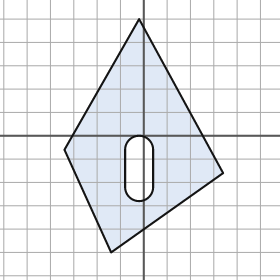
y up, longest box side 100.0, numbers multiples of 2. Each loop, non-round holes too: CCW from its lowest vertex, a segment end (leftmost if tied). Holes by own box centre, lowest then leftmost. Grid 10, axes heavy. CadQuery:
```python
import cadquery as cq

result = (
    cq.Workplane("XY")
    .moveTo(-14.0, -50.0)
    .lineTo(34.0, -16.0)
    .lineTo(-2.0, 50.0)
    .lineTo(-34.0, -6.0)
    .close()
    .moveTo(-8.0, -22.0)
    .threePointArc((-2.0, -28.0), (4.0, -22.0))
    .lineTo(4.0, -6.0)
    .threePointArc((-2.0, 0.0), (-8.0, -6.0))
    .close()
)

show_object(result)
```